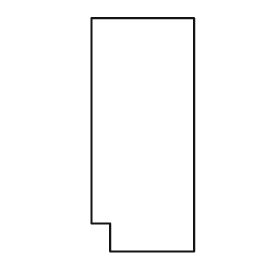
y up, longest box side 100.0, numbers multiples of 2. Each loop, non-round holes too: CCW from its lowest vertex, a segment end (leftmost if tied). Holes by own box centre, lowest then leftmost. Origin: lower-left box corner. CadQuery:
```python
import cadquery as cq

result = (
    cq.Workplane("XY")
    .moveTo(8.0, 0.0)
    .lineTo(44.0, 0.0)
    .lineTo(44.0, 100.0)
    .lineTo(0.0, 100.0)
    .lineTo(0.0, 12.0)
    .lineTo(8.0, 12.0)
    .close()
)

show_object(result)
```